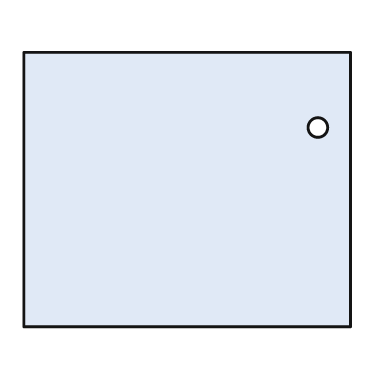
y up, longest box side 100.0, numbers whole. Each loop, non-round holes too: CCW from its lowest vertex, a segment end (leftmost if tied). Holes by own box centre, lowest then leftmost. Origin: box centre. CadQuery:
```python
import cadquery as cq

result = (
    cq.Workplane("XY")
    .moveTo(-50.0, -42.0)
    .lineTo(50.0, -42.0)
    .lineTo(50.0, 42.0)
    .lineTo(-50.0, 42.0)
    .close()
    .moveTo(40.0, 19.0)
    .circle(3.0)
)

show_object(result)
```